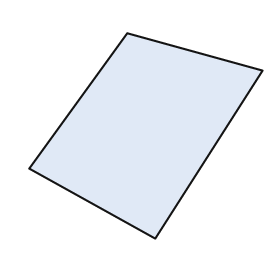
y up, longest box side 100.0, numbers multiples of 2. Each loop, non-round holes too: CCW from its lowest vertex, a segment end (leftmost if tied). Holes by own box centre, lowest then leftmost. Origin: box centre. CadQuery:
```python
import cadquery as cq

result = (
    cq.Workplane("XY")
    .moveTo(4.0, -44.0)
    .lineTo(50.0, 28.0)
    .lineTo(-8.0, 44.0)
    .lineTo(-50.0, -14.0)
    .close()
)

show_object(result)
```